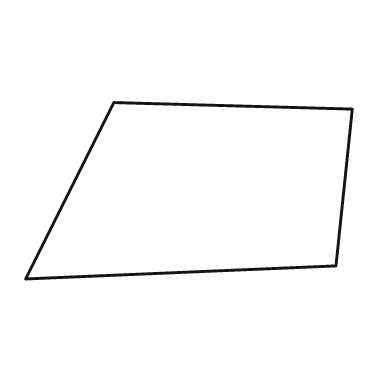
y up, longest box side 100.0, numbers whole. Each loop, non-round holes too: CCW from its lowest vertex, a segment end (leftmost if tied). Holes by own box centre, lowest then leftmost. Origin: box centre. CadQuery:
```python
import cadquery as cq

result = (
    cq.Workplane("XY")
    .moveTo(-50.0, -27.0)
    .lineTo(45.0, -23.0)
    .lineTo(50.0, 25.0)
    .lineTo(-23.0, 27.0)
    .close()
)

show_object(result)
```